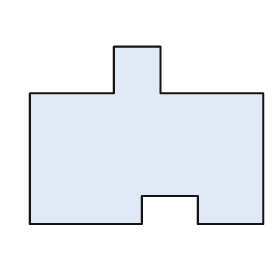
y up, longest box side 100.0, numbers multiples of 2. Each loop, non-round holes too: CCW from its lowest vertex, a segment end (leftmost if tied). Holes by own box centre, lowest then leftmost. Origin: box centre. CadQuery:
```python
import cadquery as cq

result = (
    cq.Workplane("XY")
    .moveTo(-50.0, -38.0)
    .lineTo(-2.0, -38.0)
    .lineTo(-2.0, -26.0)
    .lineTo(22.0, -26.0)
    .lineTo(22.0, -38.0)
    .lineTo(50.0, -38.0)
    .lineTo(50.0, 18.0)
    .lineTo(6.0, 18.0)
    .lineTo(6.0, 38.0)
    .lineTo(-14.0, 38.0)
    .lineTo(-14.0, 18.0)
    .lineTo(-50.0, 18.0)
    .close()
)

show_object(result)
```